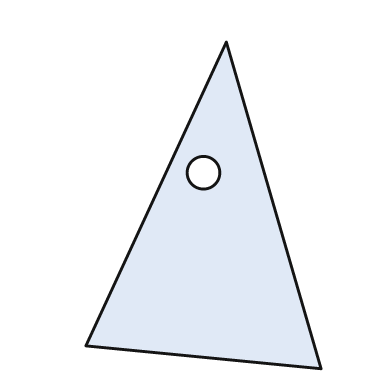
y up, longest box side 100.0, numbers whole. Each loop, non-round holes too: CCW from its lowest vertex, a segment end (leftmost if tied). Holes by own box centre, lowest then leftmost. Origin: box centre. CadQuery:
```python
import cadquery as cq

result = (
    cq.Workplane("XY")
    .moveTo(36.0, -50.0)
    .lineTo(7.0, 50.0)
    .lineTo(-36.0, -43.0)
    .close()
    .moveTo(0.0, 10.0)
    .circle(5.0)
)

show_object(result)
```